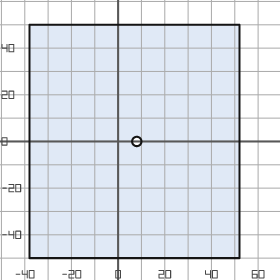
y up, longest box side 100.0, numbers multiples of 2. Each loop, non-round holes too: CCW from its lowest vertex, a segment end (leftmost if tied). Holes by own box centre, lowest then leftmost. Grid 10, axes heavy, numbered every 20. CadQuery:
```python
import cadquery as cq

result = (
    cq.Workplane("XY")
    .moveTo(-38.0, -50.0)
    .lineTo(52.0, -50.0)
    .lineTo(52.0, 50.0)
    .lineTo(-38.0, 50.0)
    .close()
    .moveTo(8.0, 0.0)
    .circle(2.0)
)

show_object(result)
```